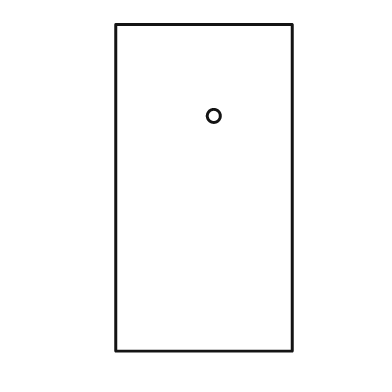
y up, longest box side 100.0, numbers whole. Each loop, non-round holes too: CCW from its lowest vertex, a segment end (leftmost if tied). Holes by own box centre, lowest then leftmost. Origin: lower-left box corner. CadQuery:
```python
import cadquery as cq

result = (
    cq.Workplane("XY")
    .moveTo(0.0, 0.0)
    .lineTo(54.0, 0.0)
    .lineTo(54.0, 100.0)
    .lineTo(0.0, 100.0)
    .close()
    .moveTo(30.0, 72.0)
    .circle(2.0)
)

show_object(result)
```